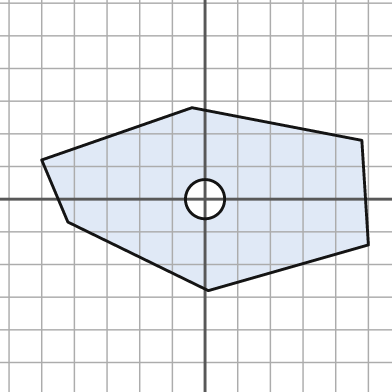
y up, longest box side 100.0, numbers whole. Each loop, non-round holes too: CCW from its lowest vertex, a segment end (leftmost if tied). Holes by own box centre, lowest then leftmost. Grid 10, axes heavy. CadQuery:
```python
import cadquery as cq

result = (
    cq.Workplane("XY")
    .moveTo(1.0, -28.0)
    .lineTo(50.0, -14.0)
    .lineTo(48.0, 18.0)
    .lineTo(-4.0, 28.0)
    .lineTo(-50.0, 12.0)
    .lineTo(-42.0, -7.0)
    .close()
    .moveTo(0.0, 0.0)
    .circle(6.0)
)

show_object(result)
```